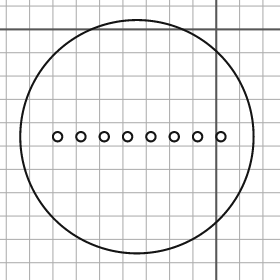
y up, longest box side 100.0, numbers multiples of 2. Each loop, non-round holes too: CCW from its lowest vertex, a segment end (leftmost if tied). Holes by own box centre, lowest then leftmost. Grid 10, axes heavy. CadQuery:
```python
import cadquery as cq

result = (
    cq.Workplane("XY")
    .moveTo(-34.0, -46.0)
    .circle(50.0)
    .moveTo(-68.0, -46.0)
    .circle(2.0)
    .moveTo(-58.0, -46.0)
    .circle(2.0)
    .moveTo(-48.0, -46.0)
    .circle(2.0)
    .moveTo(-38.0, -46.0)
    .circle(2.0)
    .moveTo(-28.0, -46.0)
    .circle(2.0)
    .moveTo(-18.0, -46.0)
    .circle(2.0)
    .moveTo(-8.0, -46.0)
    .circle(2.0)
    .moveTo(2.0, -46.0)
    .circle(2.0)
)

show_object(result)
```